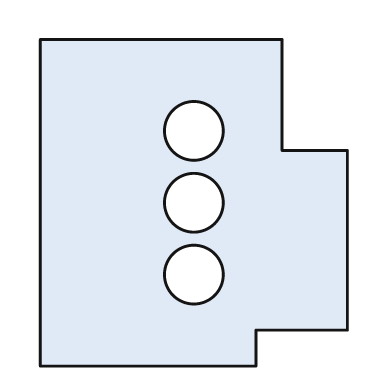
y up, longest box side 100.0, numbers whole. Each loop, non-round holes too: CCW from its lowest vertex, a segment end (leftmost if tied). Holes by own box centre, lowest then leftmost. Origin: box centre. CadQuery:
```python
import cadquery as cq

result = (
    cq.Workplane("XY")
    .moveTo(-47.0, -50.0)
    .lineTo(19.0, -50.0)
    .lineTo(19.0, -39.0)
    .lineTo(47.0, -39.0)
    .lineTo(47.0, 16.0)
    .lineTo(27.0, 16.0)
    .lineTo(27.0, 50.0)
    .lineTo(-47.0, 50.0)
    .close()
    .moveTo(0.0, -22.0)
    .circle(9.0)
    .moveTo(0.0, 0.0)
    .circle(9.0)
    .moveTo(0.0, 22.0)
    .circle(9.0)
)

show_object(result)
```